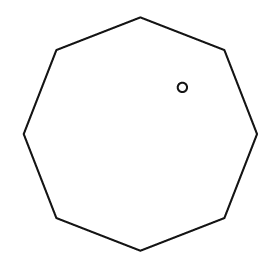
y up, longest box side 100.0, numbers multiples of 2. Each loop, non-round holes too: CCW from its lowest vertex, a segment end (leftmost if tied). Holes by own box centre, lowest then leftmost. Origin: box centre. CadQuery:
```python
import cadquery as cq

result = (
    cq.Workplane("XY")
    .moveTo(0.0, -50.0)
    .lineTo(36.0, -36.0)
    .lineTo(50.0, 0.0)
    .lineTo(36.0, 36.0)
    .lineTo(0.0, 50.0)
    .lineTo(-36.0, 36.0)
    .lineTo(-50.0, 0.0)
    .lineTo(-36.0, -36.0)
    .close()
    .moveTo(18.0, 20.0)
    .circle(2.0)
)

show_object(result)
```